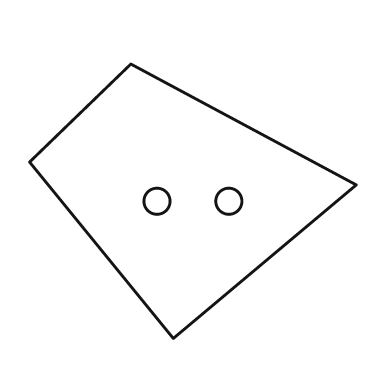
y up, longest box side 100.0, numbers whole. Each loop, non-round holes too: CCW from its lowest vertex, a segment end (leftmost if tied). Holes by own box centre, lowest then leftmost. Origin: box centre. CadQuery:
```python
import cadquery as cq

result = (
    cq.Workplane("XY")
    .moveTo(-6.0, -42.0)
    .lineTo(50.0, 5.0)
    .lineTo(-19.0, 42.0)
    .lineTo(-50.0, 12.0)
    .close()
    .moveTo(-11.0, 0.0)
    .circle(4.0)
    .moveTo(11.0, 0.0)
    .circle(4.0)
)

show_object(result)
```